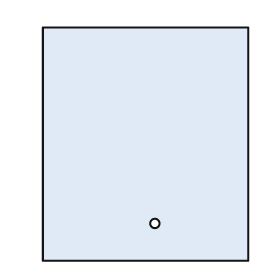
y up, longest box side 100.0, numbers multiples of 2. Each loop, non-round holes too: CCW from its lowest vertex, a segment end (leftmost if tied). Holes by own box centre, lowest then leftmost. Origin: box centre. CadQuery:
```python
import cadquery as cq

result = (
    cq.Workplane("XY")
    .moveTo(-44.0, -50.0)
    .lineTo(44.0, -50.0)
    .lineTo(44.0, 50.0)
    .lineTo(-44.0, 50.0)
    .close()
    .moveTo(4.0, -34.0)
    .circle(2.0)
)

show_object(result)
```